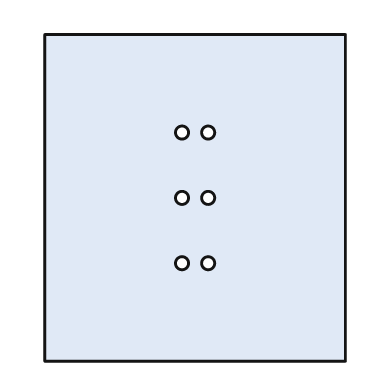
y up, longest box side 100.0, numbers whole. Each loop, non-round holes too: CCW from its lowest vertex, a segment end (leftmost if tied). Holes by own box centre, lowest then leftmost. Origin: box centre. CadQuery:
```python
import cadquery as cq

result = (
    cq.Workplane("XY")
    .moveTo(-46.0, -50.0)
    .lineTo(46.0, -50.0)
    .lineTo(46.0, 50.0)
    .lineTo(-46.0, 50.0)
    .close()
    .moveTo(-4.0, -20.0)
    .circle(2.0)
    .moveTo(4.0, -20.0)
    .circle(2.0)
    .moveTo(-4.0, 0.0)
    .circle(2.0)
    .moveTo(4.0, 0.0)
    .circle(2.0)
    .moveTo(-4.0, 20.0)
    .circle(2.0)
    .moveTo(4.0, 20.0)
    .circle(2.0)
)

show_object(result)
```